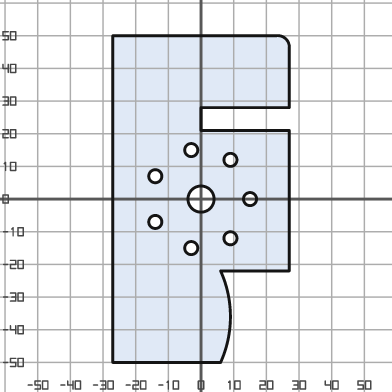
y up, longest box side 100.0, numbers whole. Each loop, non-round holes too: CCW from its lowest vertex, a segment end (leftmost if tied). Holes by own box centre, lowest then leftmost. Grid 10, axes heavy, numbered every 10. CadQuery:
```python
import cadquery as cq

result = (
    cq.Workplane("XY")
    .moveTo(-27.0, -50.0)
    .lineTo(6.0, -50.0)
    .threePointArc((9.0, -36.0), (6.0, -22.0))
    .lineTo(27.0, -22.0)
    .lineTo(27.0, 21.0)
    .lineTo(0.0, 21.0)
    .lineTo(0.0, 28.0)
    .lineTo(27.0, 28.0)
    .lineTo(27.0, 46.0)
    .threePointArc((26.0, 49.0), (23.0, 50.0))
    .lineTo(-27.0, 50.0)
    .close()
    .moveTo(-3.0, -15.0)
    .circle(2.0)
    .moveTo(9.0, -12.0)
    .circle(2.0)
    .moveTo(-14.0, -7.0)
    .circle(2.0)
    .moveTo(0.0, 0.0)
    .circle(4.0)
    .moveTo(15.0, 0.0)
    .circle(2.0)
    .moveTo(-14.0, 7.0)
    .circle(2.0)
    .moveTo(9.0, 12.0)
    .circle(2.0)
    .moveTo(-3.0, 15.0)
    .circle(2.0)
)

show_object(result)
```